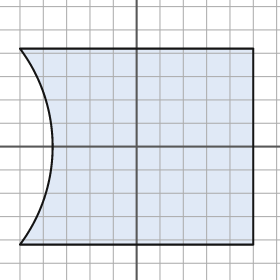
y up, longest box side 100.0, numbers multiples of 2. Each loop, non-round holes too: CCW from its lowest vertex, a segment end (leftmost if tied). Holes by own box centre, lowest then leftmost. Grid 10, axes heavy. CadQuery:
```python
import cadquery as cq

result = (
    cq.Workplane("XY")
    .moveTo(-50.0, -42.0)
    .lineTo(50.0, -42.0)
    .lineTo(50.0, 42.0)
    .lineTo(-50.0, 42.0)
    .threePointArc((-36.0, 0.0), (-50.0, -42.0))
    .close()
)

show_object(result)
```